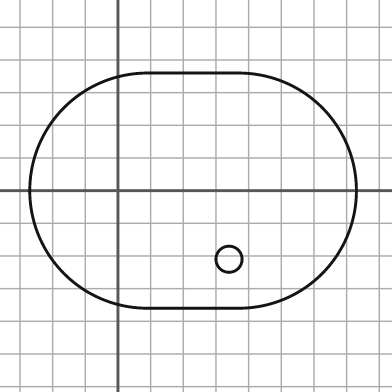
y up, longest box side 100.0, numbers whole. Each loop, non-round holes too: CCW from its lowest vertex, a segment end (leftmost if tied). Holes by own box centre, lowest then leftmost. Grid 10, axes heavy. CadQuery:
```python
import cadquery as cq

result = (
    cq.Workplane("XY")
    .moveTo(9.0, -36.0)
    .lineTo(37.0, -36.0)
    .threePointArc((73.0, 0.0), (37.0, 36.0))
    .lineTo(9.0, 36.0)
    .threePointArc((-27.0, 0.0), (9.0, -36.0))
    .close()
    .moveTo(34.0, -21.0)
    .circle(4.0)
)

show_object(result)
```